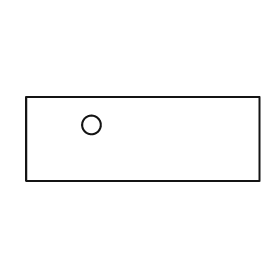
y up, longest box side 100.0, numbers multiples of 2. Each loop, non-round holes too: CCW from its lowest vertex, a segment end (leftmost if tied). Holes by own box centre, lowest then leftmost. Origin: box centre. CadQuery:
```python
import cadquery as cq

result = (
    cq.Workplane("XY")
    .moveTo(-50.0, -18.0)
    .lineTo(50.0, -18.0)
    .lineTo(50.0, 18.0)
    .lineTo(-50.0, 18.0)
    .close()
    .moveTo(-22.0, 6.0)
    .circle(4.0)
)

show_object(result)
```